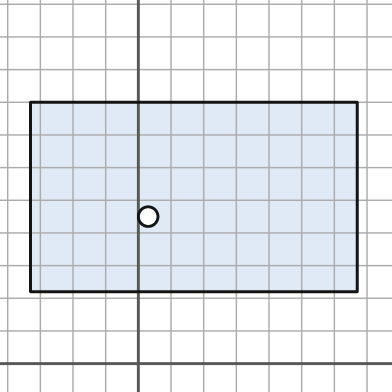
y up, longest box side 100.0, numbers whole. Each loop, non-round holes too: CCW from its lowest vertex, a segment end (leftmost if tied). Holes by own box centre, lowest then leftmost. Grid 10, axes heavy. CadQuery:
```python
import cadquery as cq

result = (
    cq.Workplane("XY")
    .moveTo(-33.0, 22.0)
    .lineTo(67.0, 22.0)
    .lineTo(67.0, 80.0)
    .lineTo(-33.0, 80.0)
    .close()
    .moveTo(3.0, 45.0)
    .circle(3.0)
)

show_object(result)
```